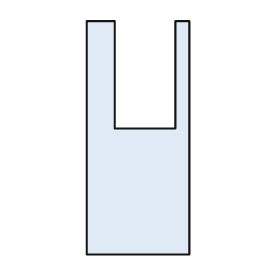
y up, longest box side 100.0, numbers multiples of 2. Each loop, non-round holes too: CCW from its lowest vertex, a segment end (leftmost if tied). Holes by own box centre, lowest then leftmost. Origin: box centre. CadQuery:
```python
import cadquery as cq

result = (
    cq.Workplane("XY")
    .moveTo(-22.0, -50.0)
    .lineTo(22.0, -50.0)
    .lineTo(22.0, 50.0)
    .lineTo(16.0, 50.0)
    .lineTo(16.0, 4.0)
    .lineTo(-10.0, 4.0)
    .lineTo(-10.0, 50.0)
    .lineTo(-22.0, 50.0)
    .close()
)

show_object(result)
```